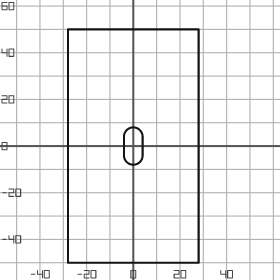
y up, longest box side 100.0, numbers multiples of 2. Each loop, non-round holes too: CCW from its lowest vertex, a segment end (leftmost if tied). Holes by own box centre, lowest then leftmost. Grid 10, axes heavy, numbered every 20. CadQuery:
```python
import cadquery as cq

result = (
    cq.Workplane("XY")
    .moveTo(-28.0, -50.0)
    .lineTo(28.0, -50.0)
    .lineTo(28.0, 50.0)
    .lineTo(-28.0, 50.0)
    .close()
    .moveTo(-4.0, -4.0)
    .threePointArc((0.0, -8.0), (4.0, -4.0))
    .lineTo(4.0, 4.0)
    .threePointArc((0.0, 8.0), (-4.0, 4.0))
    .close()
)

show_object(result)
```